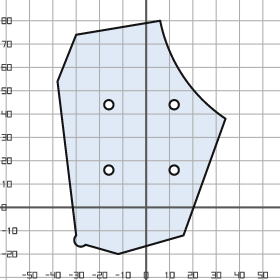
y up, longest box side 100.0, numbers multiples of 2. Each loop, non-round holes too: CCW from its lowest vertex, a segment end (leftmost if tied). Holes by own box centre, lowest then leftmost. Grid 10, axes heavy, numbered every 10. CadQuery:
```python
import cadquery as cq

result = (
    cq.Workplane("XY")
    .moveTo(-12.0, -20.0)
    .lineTo(16.0, -12.0)
    .lineTo(34.0, 38.0)
    .threePointArc((16.0, 56.0), (6.0, 80.0))
    .lineTo(-30.0, 74.0)
    .lineTo(-38.0, 54.0)
    .lineTo(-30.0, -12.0)
    .threePointArc((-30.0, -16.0), (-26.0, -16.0))
    .close()
    .moveTo(-16.0, 16.0)
    .circle(2.0)
    .moveTo(12.0, 16.0)
    .circle(2.0)
    .moveTo(-16.0, 44.0)
    .circle(2.0)
    .moveTo(12.0, 44.0)
    .circle(2.0)
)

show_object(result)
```